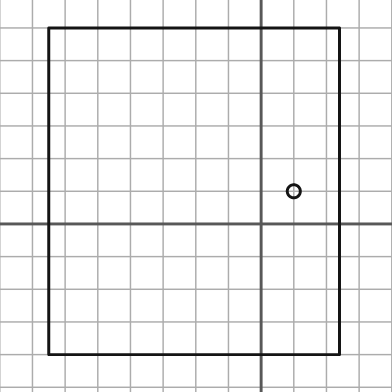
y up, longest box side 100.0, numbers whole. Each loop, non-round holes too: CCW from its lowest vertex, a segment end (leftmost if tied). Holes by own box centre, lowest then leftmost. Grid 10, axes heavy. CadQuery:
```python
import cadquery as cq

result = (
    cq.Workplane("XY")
    .moveTo(-65.0, -40.0)
    .lineTo(24.0, -40.0)
    .lineTo(24.0, 60.0)
    .lineTo(-65.0, 60.0)
    .close()
    .moveTo(10.0, 10.0)
    .circle(2.0)
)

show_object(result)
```